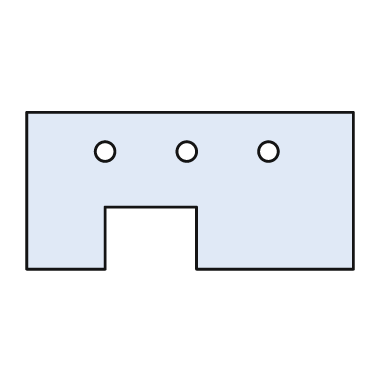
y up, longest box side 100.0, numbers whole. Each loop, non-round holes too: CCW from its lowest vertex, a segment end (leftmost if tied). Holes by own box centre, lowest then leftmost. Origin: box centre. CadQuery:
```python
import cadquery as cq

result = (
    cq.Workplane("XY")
    .moveTo(-50.0, -24.0)
    .lineTo(-26.0, -24.0)
    .lineTo(-26.0, -5.0)
    .lineTo(2.0, -5.0)
    .lineTo(2.0, -24.0)
    .lineTo(50.0, -24.0)
    .lineTo(50.0, 24.0)
    .lineTo(-50.0, 24.0)
    .close()
    .moveTo(-26.0, 12.0)
    .circle(3.0)
    .moveTo(-1.0, 12.0)
    .circle(3.0)
    .moveTo(24.0, 12.0)
    .circle(3.0)
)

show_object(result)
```